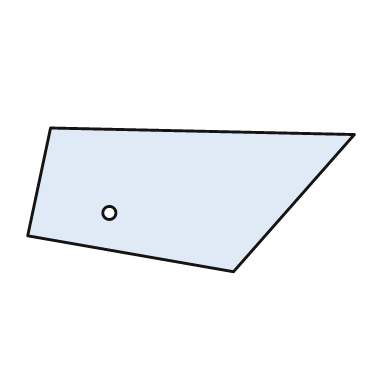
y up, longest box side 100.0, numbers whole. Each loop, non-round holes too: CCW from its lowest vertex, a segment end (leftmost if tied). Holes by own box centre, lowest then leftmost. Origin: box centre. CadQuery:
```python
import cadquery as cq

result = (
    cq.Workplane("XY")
    .moveTo(13.0, -22.0)
    .lineTo(50.0, 20.0)
    .lineTo(-43.0, 22.0)
    .lineTo(-50.0, -11.0)
    .close()
    .moveTo(-25.0, -4.0)
    .circle(2.0)
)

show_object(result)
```